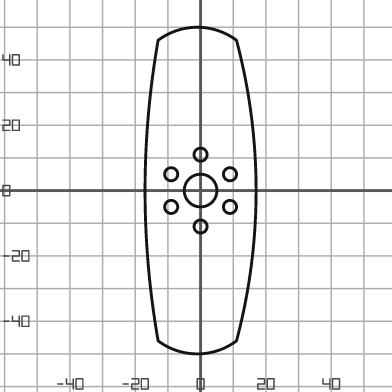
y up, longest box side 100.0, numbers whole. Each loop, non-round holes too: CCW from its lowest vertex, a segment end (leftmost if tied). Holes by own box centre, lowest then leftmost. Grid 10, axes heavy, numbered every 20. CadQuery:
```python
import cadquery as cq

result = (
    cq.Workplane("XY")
    .moveTo(-13.0, -46.0)
    .threePointArc((-1.0, -50.0), (11.0, -46.0))
    .threePointArc((17.0, 0.0), (11.0, 46.0))
    .threePointArc((-1.0, 50.0), (-13.0, 46.0))
    .threePointArc((-17.0, 0.0), (-13.0, -46.0))
    .close()
    .moveTo(0.0, -11.0)
    .circle(2.0)
    .moveTo(-9.0, -5.0)
    .circle(2.0)
    .moveTo(9.0, -5.0)
    .circle(2.0)
    .moveTo(0.0, 0.0)
    .circle(5.0)
    .moveTo(-9.0, 5.0)
    .circle(2.0)
    .moveTo(9.0, 5.0)
    .circle(2.0)
    .moveTo(0.0, 11.0)
    .circle(2.0)
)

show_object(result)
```